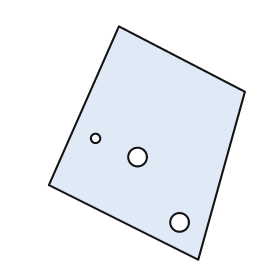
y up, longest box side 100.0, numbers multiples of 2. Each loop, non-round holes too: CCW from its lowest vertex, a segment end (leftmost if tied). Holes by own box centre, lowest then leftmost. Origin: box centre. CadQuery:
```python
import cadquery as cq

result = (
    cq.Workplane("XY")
    .moveTo(22.0, -50.0)
    .lineTo(42.0, 22.0)
    .lineTo(-12.0, 50.0)
    .lineTo(-42.0, -18.0)
    .close()
    .moveTo(14.0, -34.0)
    .circle(4.0)
    .moveTo(-4.0, -6.0)
    .circle(4.0)
    .moveTo(-22.0, 2.0)
    .circle(2.0)
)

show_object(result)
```